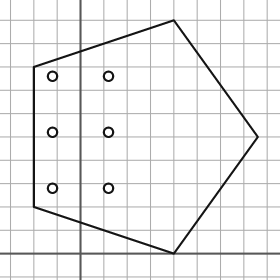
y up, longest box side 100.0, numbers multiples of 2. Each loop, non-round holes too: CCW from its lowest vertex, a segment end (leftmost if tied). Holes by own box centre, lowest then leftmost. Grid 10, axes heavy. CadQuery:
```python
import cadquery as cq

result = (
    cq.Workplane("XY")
    .moveTo(40.0, 0.0)
    .lineTo(76.0, 50.0)
    .lineTo(40.0, 100.0)
    .lineTo(-20.0, 80.0)
    .lineTo(-20.0, 20.0)
    .close()
    .moveTo(-12.0, 28.0)
    .circle(2.0)
    .moveTo(12.0, 28.0)
    .circle(2.0)
    .moveTo(-12.0, 52.0)
    .circle(2.0)
    .moveTo(12.0, 52.0)
    .circle(2.0)
    .moveTo(-12.0, 76.0)
    .circle(2.0)
    .moveTo(12.0, 76.0)
    .circle(2.0)
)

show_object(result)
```